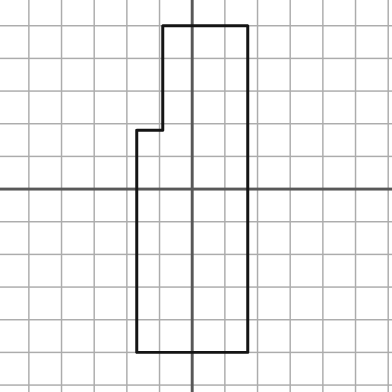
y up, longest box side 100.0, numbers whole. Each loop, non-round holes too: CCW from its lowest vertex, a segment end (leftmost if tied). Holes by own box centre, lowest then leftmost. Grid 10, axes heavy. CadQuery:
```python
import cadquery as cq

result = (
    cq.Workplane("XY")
    .moveTo(-17.0, -50.0)
    .lineTo(17.0, -50.0)
    .lineTo(17.0, 50.0)
    .lineTo(-9.0, 50.0)
    .lineTo(-9.0, 18.0)
    .lineTo(-17.0, 18.0)
    .close()
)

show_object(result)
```